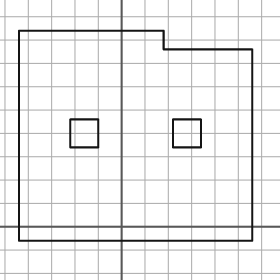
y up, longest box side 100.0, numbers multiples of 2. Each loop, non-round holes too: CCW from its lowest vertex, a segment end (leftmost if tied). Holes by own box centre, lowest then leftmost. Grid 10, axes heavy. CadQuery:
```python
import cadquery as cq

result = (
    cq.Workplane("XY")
    .moveTo(-44.0, -6.0)
    .lineTo(56.0, -6.0)
    .lineTo(56.0, 76.0)
    .lineTo(18.0, 76.0)
    .lineTo(18.0, 84.0)
    .lineTo(-44.0, 84.0)
    .close()
    .moveTo(-22.0, 34.0)
    .lineTo(-10.0, 34.0)
    .lineTo(-10.0, 46.0)
    .lineTo(-22.0, 46.0)
    .close()
    .moveTo(22.0, 34.0)
    .lineTo(34.0, 34.0)
    .lineTo(34.0, 46.0)
    .lineTo(22.0, 46.0)
    .close()
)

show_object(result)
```